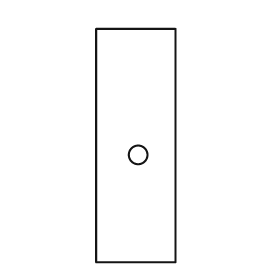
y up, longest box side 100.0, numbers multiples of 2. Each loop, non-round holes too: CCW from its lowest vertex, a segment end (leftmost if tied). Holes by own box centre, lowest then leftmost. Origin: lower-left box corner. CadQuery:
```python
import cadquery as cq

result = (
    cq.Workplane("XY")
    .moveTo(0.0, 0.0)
    .lineTo(34.0, 0.0)
    .lineTo(34.0, 100.0)
    .lineTo(0.0, 100.0)
    .close()
    .moveTo(18.0, 46.0)
    .circle(4.0)
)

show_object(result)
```